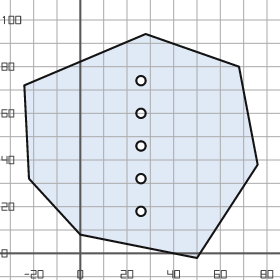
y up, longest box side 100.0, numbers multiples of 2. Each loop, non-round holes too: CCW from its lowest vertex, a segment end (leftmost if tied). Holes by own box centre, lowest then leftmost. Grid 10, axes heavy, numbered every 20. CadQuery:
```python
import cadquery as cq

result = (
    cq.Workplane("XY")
    .moveTo(50.0, -2.0)
    .lineTo(76.0, 38.0)
    .lineTo(68.0, 80.0)
    .lineTo(28.0, 94.0)
    .lineTo(-24.0, 72.0)
    .lineTo(-22.0, 32.0)
    .lineTo(0.0, 8.0)
    .close()
    .moveTo(26.0, 18.0)
    .circle(2.0)
    .moveTo(26.0, 32.0)
    .circle(2.0)
    .moveTo(26.0, 46.0)
    .circle(2.0)
    .moveTo(26.0, 60.0)
    .circle(2.0)
    .moveTo(26.0, 74.0)
    .circle(2.0)
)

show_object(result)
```